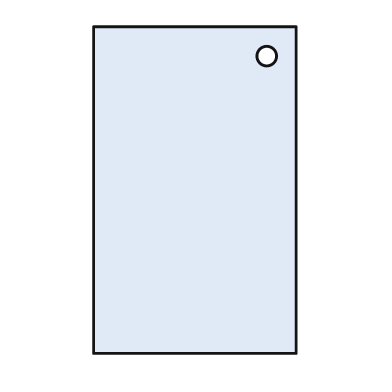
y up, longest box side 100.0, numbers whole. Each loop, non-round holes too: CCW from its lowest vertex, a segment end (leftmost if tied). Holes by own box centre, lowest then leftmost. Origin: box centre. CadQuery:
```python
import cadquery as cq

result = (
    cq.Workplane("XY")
    .moveTo(-31.0, -50.0)
    .lineTo(31.0, -50.0)
    .lineTo(31.0, 50.0)
    .lineTo(-31.0, 50.0)
    .close()
    .moveTo(22.0, 41.0)
    .circle(3.0)
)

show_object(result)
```